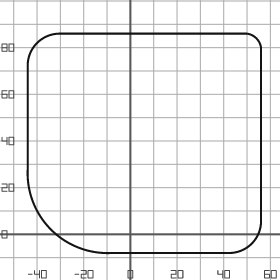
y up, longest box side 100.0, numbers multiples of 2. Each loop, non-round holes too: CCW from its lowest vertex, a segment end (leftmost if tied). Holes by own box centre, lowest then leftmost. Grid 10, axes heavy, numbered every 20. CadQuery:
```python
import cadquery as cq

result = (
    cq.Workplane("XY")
    .moveTo(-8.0, -8.0)
    .lineTo(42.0, -8.0)
    .threePointArc((52.0, -4.0), (56.0, 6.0))
    .lineTo(56.0, 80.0)
    .threePointArc((54.0, 84.0), (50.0, 86.0))
    .lineTo(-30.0, 86.0)
    .threePointArc((-40.0, 82.0), (-44.0, 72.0))
    .lineTo(-44.0, 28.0)
    .threePointArc((-34.0, 2.0), (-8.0, -8.0))
    .close()
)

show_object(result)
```